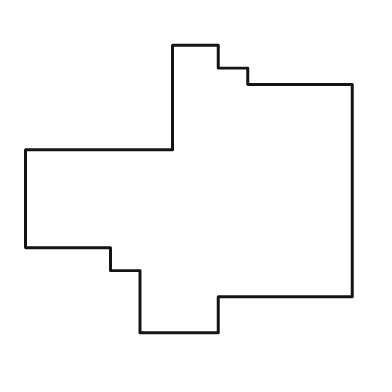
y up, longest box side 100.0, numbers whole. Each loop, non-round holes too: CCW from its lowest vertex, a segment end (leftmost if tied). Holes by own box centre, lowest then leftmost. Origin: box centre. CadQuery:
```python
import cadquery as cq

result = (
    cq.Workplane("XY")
    .moveTo(-15.0, -44.0)
    .lineTo(9.0, -44.0)
    .lineTo(9.0, -33.0)
    .lineTo(50.0, -33.0)
    .lineTo(50.0, 32.0)
    .lineTo(18.0, 32.0)
    .lineTo(18.0, 37.0)
    .lineTo(9.0, 37.0)
    .lineTo(9.0, 44.0)
    .lineTo(-5.0, 44.0)
    .lineTo(-5.0, 12.0)
    .lineTo(-50.0, 12.0)
    .lineTo(-50.0, -18.0)
    .lineTo(-24.0, -18.0)
    .lineTo(-24.0, -25.0)
    .lineTo(-15.0, -25.0)
    .close()
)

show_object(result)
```